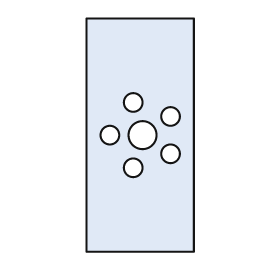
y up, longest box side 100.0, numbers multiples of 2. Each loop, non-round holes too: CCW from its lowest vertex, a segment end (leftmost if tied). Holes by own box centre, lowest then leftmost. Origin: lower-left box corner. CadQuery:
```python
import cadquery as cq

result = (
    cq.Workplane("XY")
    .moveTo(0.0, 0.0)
    .lineTo(46.0, 0.0)
    .lineTo(46.0, 100.0)
    .lineTo(0.0, 100.0)
    .close()
    .moveTo(20.0, 36.0)
    .circle(4.0)
    .moveTo(36.0, 42.0)
    .circle(4.0)
    .moveTo(10.0, 50.0)
    .circle(4.0)
    .moveTo(24.0, 50.0)
    .circle(6.0)
    .moveTo(36.0, 58.0)
    .circle(4.0)
    .moveTo(20.0, 64.0)
    .circle(4.0)
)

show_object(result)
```